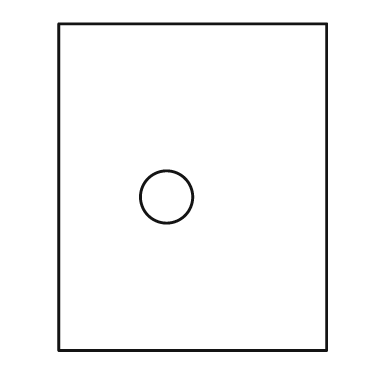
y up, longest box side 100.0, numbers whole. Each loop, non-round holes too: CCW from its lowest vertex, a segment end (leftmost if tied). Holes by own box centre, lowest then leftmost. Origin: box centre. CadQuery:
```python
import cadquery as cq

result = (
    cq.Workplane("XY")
    .moveTo(-41.0, -50.0)
    .lineTo(41.0, -50.0)
    .lineTo(41.0, 50.0)
    .lineTo(-41.0, 50.0)
    .close()
    .moveTo(-8.0, -3.0)
    .circle(8.0)
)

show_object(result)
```